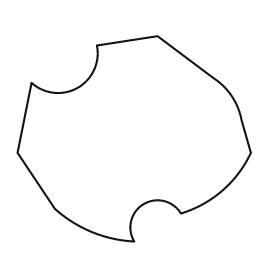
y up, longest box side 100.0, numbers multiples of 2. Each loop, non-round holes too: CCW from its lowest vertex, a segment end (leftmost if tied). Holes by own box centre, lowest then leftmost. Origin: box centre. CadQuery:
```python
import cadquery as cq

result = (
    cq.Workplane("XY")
    .moveTo(0.0, -44.0)
    .threePointArc((4.0, -28.0), (20.0, -32.0))
    .threePointArc((38.0, -22.0), (50.0, -6.0))
    .lineTo(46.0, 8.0)
    .threePointArc((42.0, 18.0), (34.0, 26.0))
    .lineTo(10.0, 44.0)
    .lineTo(-16.0, 40.0)
    .threePointArc((-24.0, 22.0), (-44.0, 24.0))
    .lineTo(-50.0, -6.0)
    .lineTo(-34.0, -30.0)
    .threePointArc((-18.0, -40.0), (0.0, -44.0))
    .close()
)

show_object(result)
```